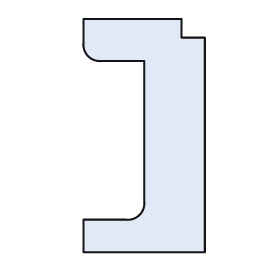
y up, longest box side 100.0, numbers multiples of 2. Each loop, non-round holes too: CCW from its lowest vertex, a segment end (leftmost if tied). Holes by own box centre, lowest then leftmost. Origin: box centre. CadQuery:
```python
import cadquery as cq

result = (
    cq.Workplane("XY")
    .moveTo(-26.0, -50.0)
    .lineTo(26.0, -50.0)
    .lineTo(26.0, 42.0)
    .lineTo(16.0, 42.0)
    .lineTo(16.0, 50.0)
    .lineTo(-26.0, 50.0)
    .lineTo(-26.0, 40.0)
    .threePointArc((-24.0, 34.0), (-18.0, 32.0))
    .lineTo(0.0, 32.0)
    .lineTo(0.0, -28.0)
    .threePointArc((-2.0, -34.0), (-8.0, -36.0))
    .lineTo(-26.0, -36.0)
    .close()
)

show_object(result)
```